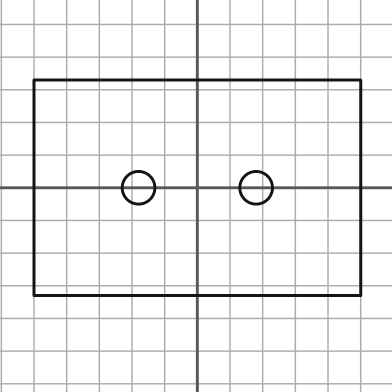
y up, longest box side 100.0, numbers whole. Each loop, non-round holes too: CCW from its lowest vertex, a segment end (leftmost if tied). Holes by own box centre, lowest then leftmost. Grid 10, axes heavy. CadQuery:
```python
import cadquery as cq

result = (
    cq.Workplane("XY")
    .moveTo(-50.0, -33.0)
    .lineTo(50.0, -33.0)
    .lineTo(50.0, 33.0)
    .lineTo(-50.0, 33.0)
    .close()
    .moveTo(-18.0, 0.0)
    .circle(5.0)
    .moveTo(18.0, 0.0)
    .circle(5.0)
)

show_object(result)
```